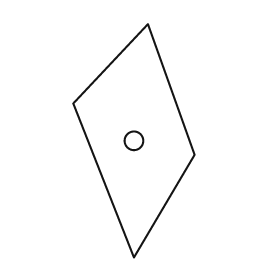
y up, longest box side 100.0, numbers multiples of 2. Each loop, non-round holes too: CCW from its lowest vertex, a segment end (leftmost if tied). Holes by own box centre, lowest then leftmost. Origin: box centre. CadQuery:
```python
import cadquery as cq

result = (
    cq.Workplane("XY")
    .moveTo(0.0, -50.0)
    .lineTo(26.0, -6.0)
    .lineTo(6.0, 50.0)
    .lineTo(-26.0, 16.0)
    .close()
    .moveTo(0.0, 0.0)
    .circle(4.0)
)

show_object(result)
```